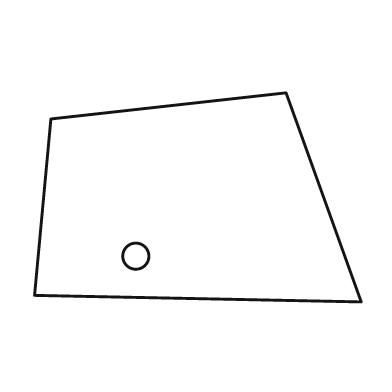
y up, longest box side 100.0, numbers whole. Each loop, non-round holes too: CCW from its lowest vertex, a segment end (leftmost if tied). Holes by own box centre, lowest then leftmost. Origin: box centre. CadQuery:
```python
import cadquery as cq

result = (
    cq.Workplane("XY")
    .moveTo(50.0, -32.0)
    .lineTo(27.0, 32.0)
    .lineTo(-45.0, 24.0)
    .lineTo(-50.0, -30.0)
    .close()
    .moveTo(-19.0, -18.0)
    .circle(4.0)
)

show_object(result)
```